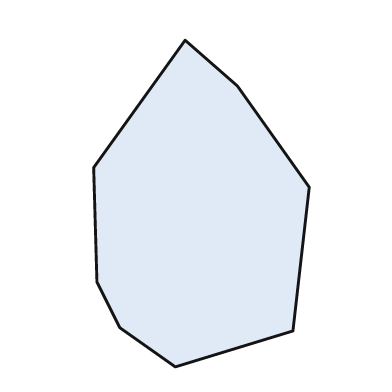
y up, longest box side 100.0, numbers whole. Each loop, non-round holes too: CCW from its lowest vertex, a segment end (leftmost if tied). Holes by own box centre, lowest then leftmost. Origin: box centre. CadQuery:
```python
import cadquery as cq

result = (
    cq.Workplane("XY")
    .moveTo(-8.0, -50.0)
    .lineTo(28.0, -39.0)
    .lineTo(33.0, 5.0)
    .lineTo(11.0, 36.0)
    .lineTo(-5.0, 50.0)
    .lineTo(-33.0, 11.0)
    .lineTo(-32.0, -24.0)
    .lineTo(-25.0, -38.0)
    .close()
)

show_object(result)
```